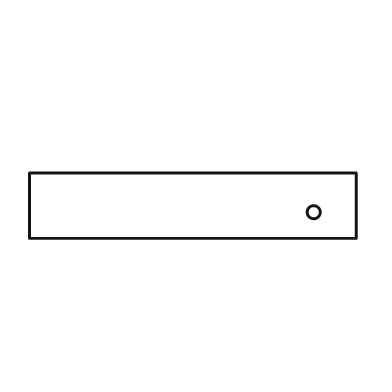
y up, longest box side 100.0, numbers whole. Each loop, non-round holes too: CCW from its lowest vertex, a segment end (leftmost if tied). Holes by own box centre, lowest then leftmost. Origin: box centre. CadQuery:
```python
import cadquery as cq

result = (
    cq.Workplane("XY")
    .moveTo(-50.0, -10.0)
    .lineTo(50.0, -10.0)
    .lineTo(50.0, 10.0)
    .lineTo(-50.0, 10.0)
    .close()
    .moveTo(37.0, -2.0)
    .circle(2.0)
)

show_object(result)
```